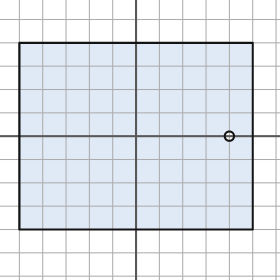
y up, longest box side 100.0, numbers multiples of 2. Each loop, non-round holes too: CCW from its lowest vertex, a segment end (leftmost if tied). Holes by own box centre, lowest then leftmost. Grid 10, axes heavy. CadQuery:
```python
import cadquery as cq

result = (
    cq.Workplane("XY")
    .moveTo(-50.0, -40.0)
    .lineTo(50.0, -40.0)
    .lineTo(50.0, 40.0)
    .lineTo(-50.0, 40.0)
    .close()
    .moveTo(40.0, 0.0)
    .circle(2.0)
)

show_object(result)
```